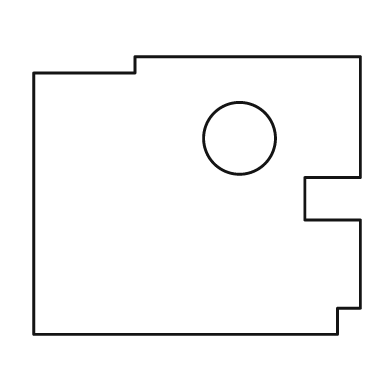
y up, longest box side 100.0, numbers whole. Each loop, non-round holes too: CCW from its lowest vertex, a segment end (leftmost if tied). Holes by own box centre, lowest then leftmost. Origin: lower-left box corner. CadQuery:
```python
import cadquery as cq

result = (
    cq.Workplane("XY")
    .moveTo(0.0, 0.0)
    .lineTo(93.0, 0.0)
    .lineTo(93.0, 8.0)
    .lineTo(100.0, 8.0)
    .lineTo(100.0, 35.0)
    .lineTo(83.0, 35.0)
    .lineTo(83.0, 48.0)
    .lineTo(100.0, 48.0)
    .lineTo(100.0, 85.0)
    .lineTo(31.0, 85.0)
    .lineTo(31.0, 80.0)
    .lineTo(0.0, 80.0)
    .close()
    .moveTo(63.0, 60.0)
    .circle(11.0)
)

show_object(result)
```